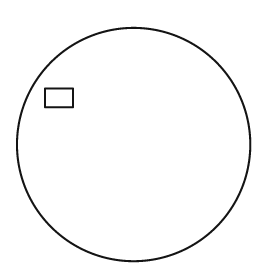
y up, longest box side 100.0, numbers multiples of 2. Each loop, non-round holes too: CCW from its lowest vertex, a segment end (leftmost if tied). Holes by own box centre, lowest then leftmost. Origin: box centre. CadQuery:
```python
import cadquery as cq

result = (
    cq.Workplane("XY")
    .moveTo(0.0, 0.0)
    .circle(50.0)
    .moveTo(-38.0, 16.0)
    .lineTo(-26.0, 16.0)
    .lineTo(-26.0, 24.0)
    .lineTo(-38.0, 24.0)
    .close()
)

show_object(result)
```